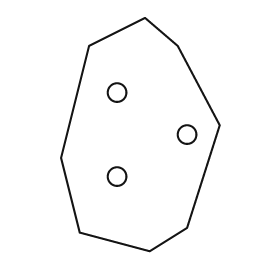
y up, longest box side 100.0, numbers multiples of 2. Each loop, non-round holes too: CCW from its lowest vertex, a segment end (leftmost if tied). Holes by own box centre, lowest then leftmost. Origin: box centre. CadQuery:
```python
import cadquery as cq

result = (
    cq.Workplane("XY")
    .moveTo(4.0, -50.0)
    .lineTo(20.0, -40.0)
    .lineTo(34.0, 4.0)
    .lineTo(16.0, 38.0)
    .lineTo(2.0, 50.0)
    .lineTo(-22.0, 38.0)
    .lineTo(-34.0, -10.0)
    .lineTo(-26.0, -42.0)
    .close()
    .moveTo(-10.0, -18.0)
    .circle(4.0)
    .moveTo(20.0, 0.0)
    .circle(4.0)
    .moveTo(-10.0, 18.0)
    .circle(4.0)
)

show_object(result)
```